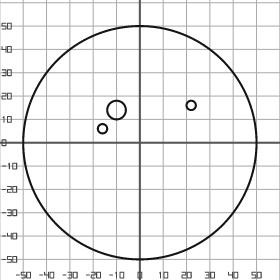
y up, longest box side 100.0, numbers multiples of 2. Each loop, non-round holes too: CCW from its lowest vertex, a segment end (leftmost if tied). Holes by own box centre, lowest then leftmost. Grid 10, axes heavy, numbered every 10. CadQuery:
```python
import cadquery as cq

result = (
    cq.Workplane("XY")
    .moveTo(0.0, 0.0)
    .circle(50.0)
    .moveTo(-16.0, 6.0)
    .circle(2.0)
    .moveTo(-10.0, 14.0)
    .circle(4.0)
    .moveTo(22.0, 16.0)
    .circle(2.0)
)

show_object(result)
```